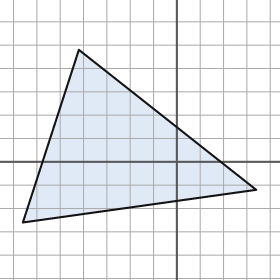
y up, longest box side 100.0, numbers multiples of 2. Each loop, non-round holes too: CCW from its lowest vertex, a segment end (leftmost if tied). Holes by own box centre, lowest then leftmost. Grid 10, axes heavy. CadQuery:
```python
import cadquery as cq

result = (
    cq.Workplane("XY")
    .moveTo(-66.0, -26.0)
    .lineTo(34.0, -12.0)
    .lineTo(-42.0, 48.0)
    .close()
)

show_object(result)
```